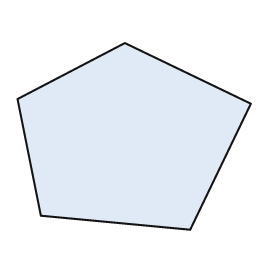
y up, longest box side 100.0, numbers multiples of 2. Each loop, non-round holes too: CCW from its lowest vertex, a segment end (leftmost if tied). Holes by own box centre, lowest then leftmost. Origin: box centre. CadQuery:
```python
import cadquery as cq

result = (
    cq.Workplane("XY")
    .moveTo(24.0, -40.0)
    .lineTo(50.0, 14.0)
    .lineTo(-4.0, 40.0)
    .lineTo(-50.0, 16.0)
    .lineTo(-40.0, -34.0)
    .close()
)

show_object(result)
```